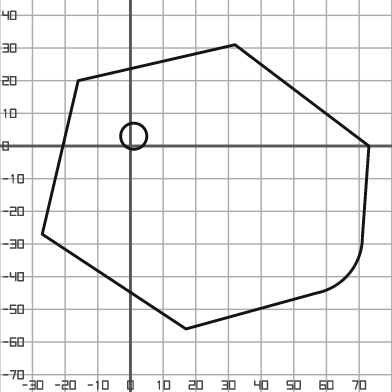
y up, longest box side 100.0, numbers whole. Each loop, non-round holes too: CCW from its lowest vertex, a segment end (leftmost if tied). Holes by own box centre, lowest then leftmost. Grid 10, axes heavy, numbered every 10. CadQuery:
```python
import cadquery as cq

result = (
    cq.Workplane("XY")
    .moveTo(17.0, -56.0)
    .lineTo(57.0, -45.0)
    .threePointArc((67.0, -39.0), (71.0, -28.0))
    .lineTo(73.0, 0.0)
    .lineTo(32.0, 31.0)
    .lineTo(-16.0, 20.0)
    .lineTo(-27.0, -27.0)
    .close()
    .moveTo(1.0, 3.0)
    .circle(4.0)
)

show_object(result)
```